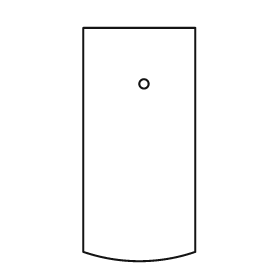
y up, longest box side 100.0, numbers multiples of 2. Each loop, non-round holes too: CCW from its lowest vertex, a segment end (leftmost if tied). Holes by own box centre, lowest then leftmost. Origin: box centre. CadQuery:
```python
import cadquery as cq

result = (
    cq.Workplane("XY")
    .moveTo(-24.0, -46.0)
    .threePointArc((0.0, -50.0), (24.0, -46.0))
    .lineTo(24.0, 50.0)
    .lineTo(-24.0, 50.0)
    .close()
    .moveTo(2.0, 26.0)
    .circle(2.0)
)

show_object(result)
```